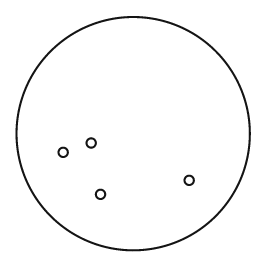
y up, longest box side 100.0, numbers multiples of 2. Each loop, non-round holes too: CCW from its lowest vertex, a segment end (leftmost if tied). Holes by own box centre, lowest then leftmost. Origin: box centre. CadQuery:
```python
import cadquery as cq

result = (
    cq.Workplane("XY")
    .moveTo(0.0, 0.0)
    .circle(50.0)
    .moveTo(-14.0, -26.0)
    .circle(2.0)
    .moveTo(24.0, -20.0)
    .circle(2.0)
    .moveTo(-30.0, -8.0)
    .circle(2.0)
    .moveTo(-18.0, -4.0)
    .circle(2.0)
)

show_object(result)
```